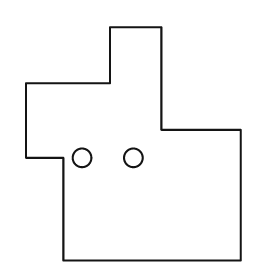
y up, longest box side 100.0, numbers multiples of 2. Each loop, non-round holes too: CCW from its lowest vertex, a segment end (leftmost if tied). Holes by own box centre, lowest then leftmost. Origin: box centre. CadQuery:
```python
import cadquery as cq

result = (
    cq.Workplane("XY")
    .moveTo(-30.0, -50.0)
    .lineTo(46.0, -50.0)
    .lineTo(46.0, 6.0)
    .lineTo(12.0, 6.0)
    .lineTo(12.0, 50.0)
    .lineTo(-10.0, 50.0)
    .lineTo(-10.0, 26.0)
    .lineTo(-46.0, 26.0)
    .lineTo(-46.0, -6.0)
    .lineTo(-30.0, -6.0)
    .close()
    .moveTo(-22.0, -6.0)
    .circle(4.0)
    .moveTo(0.0, -6.0)
    .circle(4.0)
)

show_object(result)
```